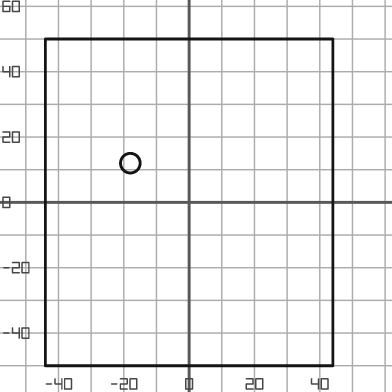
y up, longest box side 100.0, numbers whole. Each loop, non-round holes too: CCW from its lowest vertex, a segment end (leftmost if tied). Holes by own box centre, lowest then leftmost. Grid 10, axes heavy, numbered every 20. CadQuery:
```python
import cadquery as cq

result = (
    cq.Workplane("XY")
    .moveTo(-44.0, -50.0)
    .lineTo(44.0, -50.0)
    .lineTo(44.0, 50.0)
    .lineTo(-44.0, 50.0)
    .close()
    .moveTo(-18.0, 12.0)
    .circle(3.0)
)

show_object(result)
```